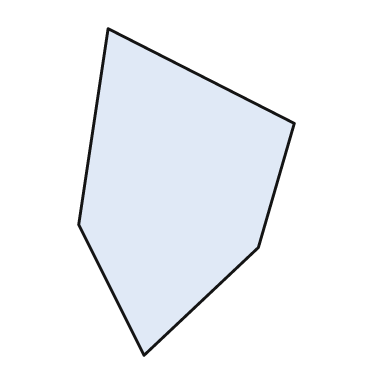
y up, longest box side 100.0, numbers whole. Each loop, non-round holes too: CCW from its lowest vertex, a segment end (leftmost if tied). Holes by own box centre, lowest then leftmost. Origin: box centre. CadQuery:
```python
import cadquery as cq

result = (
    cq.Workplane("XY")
    .moveTo(-13.0, -50.0)
    .lineTo(22.0, -17.0)
    .lineTo(33.0, 21.0)
    .lineTo(-24.0, 50.0)
    .lineTo(-33.0, -10.0)
    .close()
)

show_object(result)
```